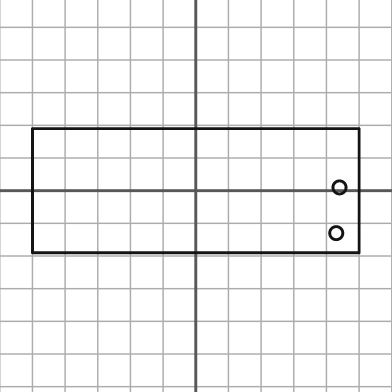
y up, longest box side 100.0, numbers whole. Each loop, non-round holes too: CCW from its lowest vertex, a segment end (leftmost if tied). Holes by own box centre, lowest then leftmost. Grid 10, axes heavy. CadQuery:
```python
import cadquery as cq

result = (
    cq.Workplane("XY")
    .moveTo(-50.0, -19.0)
    .lineTo(50.0, -19.0)
    .lineTo(50.0, 19.0)
    .lineTo(-50.0, 19.0)
    .close()
    .moveTo(43.0, -13.0)
    .circle(2.0)
    .moveTo(44.0, 1.0)
    .circle(2.0)
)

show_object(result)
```